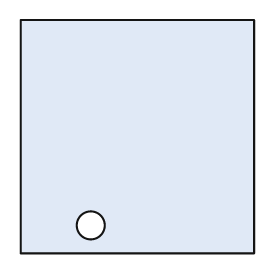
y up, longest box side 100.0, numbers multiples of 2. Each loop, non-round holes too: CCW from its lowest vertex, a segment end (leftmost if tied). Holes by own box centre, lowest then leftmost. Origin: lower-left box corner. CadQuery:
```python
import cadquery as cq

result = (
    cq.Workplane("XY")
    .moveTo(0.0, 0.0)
    .lineTo(100.0, 0.0)
    .lineTo(100.0, 100.0)
    .lineTo(0.0, 100.0)
    .close()
    .moveTo(30.0, 12.0)
    .circle(6.0)
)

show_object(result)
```